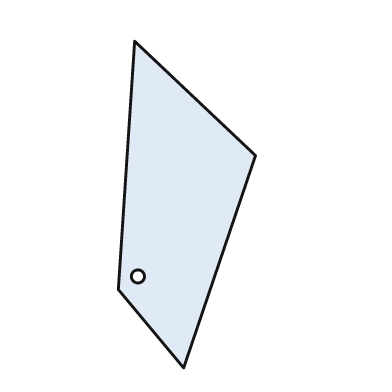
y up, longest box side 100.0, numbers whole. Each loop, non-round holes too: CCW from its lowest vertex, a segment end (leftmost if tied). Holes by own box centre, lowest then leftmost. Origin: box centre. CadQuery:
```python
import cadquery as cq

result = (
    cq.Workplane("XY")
    .moveTo(-1.0, -50.0)
    .lineTo(21.0, 15.0)
    .lineTo(-16.0, 50.0)
    .lineTo(-21.0, -26.0)
    .close()
    .moveTo(-15.0, -22.0)
    .circle(2.0)
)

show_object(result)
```